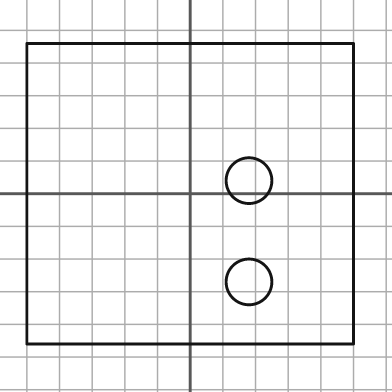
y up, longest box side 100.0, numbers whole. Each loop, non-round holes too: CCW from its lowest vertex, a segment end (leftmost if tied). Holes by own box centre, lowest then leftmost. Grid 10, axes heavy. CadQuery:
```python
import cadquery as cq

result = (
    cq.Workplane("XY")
    .moveTo(-50.0, -46.0)
    .lineTo(50.0, -46.0)
    .lineTo(50.0, 46.0)
    .lineTo(-50.0, 46.0)
    .close()
    .moveTo(18.0, -27.0)
    .circle(7.0)
    .moveTo(18.0, 4.0)
    .circle(7.0)
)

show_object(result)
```